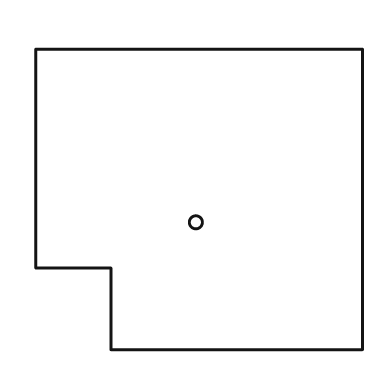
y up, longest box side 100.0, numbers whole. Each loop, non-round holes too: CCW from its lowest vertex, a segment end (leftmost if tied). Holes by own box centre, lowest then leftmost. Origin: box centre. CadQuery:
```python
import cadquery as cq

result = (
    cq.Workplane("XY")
    .moveTo(-27.0, -46.0)
    .lineTo(50.0, -46.0)
    .lineTo(50.0, 46.0)
    .lineTo(-50.0, 46.0)
    .lineTo(-50.0, -21.0)
    .lineTo(-27.0, -21.0)
    .close()
    .moveTo(-1.0, -7.0)
    .circle(2.0)
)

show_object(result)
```